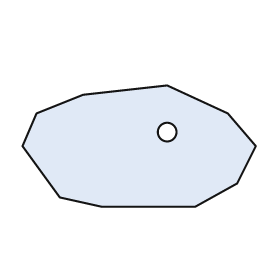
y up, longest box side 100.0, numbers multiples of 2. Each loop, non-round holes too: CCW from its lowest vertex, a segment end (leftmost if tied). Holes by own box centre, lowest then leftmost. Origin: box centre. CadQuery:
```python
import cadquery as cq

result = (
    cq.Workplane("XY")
    .moveTo(-16.0, -26.0)
    .lineTo(24.0, -26.0)
    .lineTo(42.0, -16.0)
    .lineTo(50.0, 0.0)
    .lineTo(38.0, 14.0)
    .lineTo(12.0, 26.0)
    .lineTo(-24.0, 22.0)
    .lineTo(-44.0, 14.0)
    .lineTo(-50.0, 0.0)
    .lineTo(-34.0, -22.0)
    .close()
    .moveTo(12.0, 6.0)
    .circle(4.0)
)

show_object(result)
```